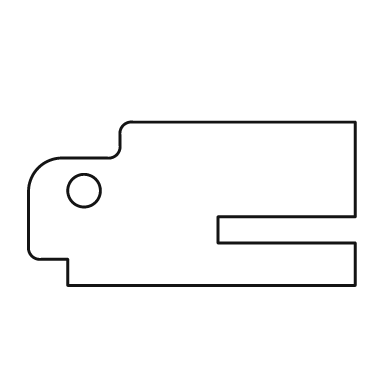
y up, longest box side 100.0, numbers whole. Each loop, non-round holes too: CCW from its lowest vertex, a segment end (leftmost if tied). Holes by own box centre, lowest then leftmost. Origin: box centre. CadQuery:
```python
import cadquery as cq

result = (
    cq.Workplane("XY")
    .moveTo(-38.0, -25.0)
    .lineTo(50.0, -25.0)
    .lineTo(50.0, -12.0)
    .lineTo(8.0, -12.0)
    .lineTo(8.0, -4.0)
    .lineTo(50.0, -4.0)
    .lineTo(50.0, 25.0)
    .lineTo(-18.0, 25.0)
    .threePointArc((-21.0, 24.0), (-22.0, 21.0))
    .lineTo(-22.0, 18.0)
    .threePointArc((-23.0, 15.0), (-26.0, 14.0))
    .lineTo(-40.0, 14.0)
    .threePointArc((-47.0, 11.0), (-50.0, 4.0))
    .lineTo(-50.0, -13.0)
    .threePointArc((-49.0, -16.0), (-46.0, -17.0))
    .lineTo(-38.0, -17.0)
    .close()
    .moveTo(-33.0, 4.0)
    .circle(5.0)
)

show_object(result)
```